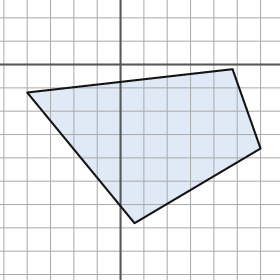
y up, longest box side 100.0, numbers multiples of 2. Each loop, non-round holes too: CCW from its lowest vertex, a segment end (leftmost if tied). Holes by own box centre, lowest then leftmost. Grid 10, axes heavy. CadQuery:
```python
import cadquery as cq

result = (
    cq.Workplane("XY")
    .moveTo(6.0, -68.0)
    .lineTo(60.0, -36.0)
    .lineTo(48.0, -2.0)
    .lineTo(-40.0, -12.0)
    .close()
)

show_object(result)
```